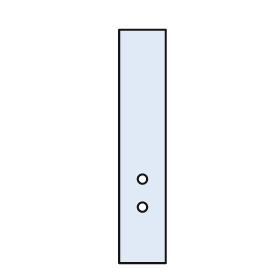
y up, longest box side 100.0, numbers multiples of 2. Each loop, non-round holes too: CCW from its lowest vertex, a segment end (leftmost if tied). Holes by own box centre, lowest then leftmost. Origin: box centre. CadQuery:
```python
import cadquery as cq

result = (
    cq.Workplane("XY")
    .moveTo(-10.0, -50.0)
    .lineTo(10.0, -50.0)
    .lineTo(10.0, 50.0)
    .lineTo(-10.0, 50.0)
    .close()
    .moveTo(0.0, -26.0)
    .circle(2.0)
    .moveTo(0.0, -14.0)
    .circle(2.0)
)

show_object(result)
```